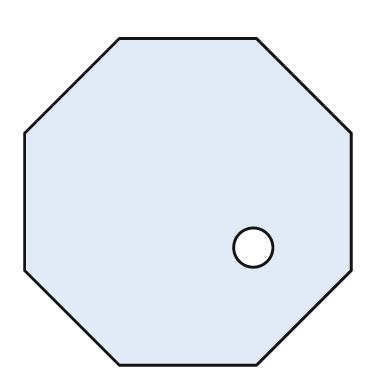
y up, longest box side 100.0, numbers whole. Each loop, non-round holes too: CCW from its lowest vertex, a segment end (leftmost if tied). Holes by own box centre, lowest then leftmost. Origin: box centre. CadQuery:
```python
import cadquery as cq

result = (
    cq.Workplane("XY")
    .moveTo(-21.0, -50.0)
    .lineTo(21.0, -50.0)
    .lineTo(50.0, -21.0)
    .lineTo(50.0, 21.0)
    .lineTo(21.0, 50.0)
    .lineTo(-21.0, 50.0)
    .lineTo(-50.0, 21.0)
    .lineTo(-50.0, -21.0)
    .close()
    .moveTo(20.0, -14.0)
    .circle(6.0)
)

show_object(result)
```